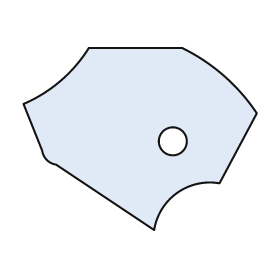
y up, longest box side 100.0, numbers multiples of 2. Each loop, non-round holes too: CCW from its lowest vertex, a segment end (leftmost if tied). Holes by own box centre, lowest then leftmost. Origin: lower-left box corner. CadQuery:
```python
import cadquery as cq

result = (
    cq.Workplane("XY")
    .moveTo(56.0, 0.0)
    .threePointArc((66.0, 16.0), (84.0, 20.0))
    .lineTo(100.0, 50.0)
    .threePointArc((86.0, 66.0), (68.0, 78.0))
    .lineTo(28.0, 78.0)
    .threePointArc((16.0, 64.0), (0.0, 54.0))
    .lineTo(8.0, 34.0)
    .threePointArc((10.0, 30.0), (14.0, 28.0))
    .close()
    .moveTo(64.0, 38.0)
    .circle(6.0)
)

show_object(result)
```